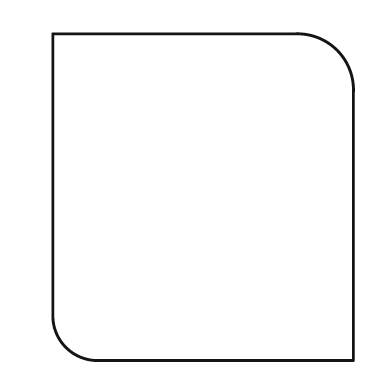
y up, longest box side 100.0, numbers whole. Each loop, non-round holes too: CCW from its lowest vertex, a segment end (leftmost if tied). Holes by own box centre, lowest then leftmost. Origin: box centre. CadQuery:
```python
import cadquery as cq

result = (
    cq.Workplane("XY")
    .moveTo(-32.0, -50.0)
    .lineTo(46.0, -50.0)
    .lineTo(46.0, 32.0)
    .threePointArc((41.0, 45.0), (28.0, 50.0))
    .lineTo(-46.0, 50.0)
    .lineTo(-46.0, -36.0)
    .threePointArc((-42.0, -46.0), (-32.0, -50.0))
    .close()
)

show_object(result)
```